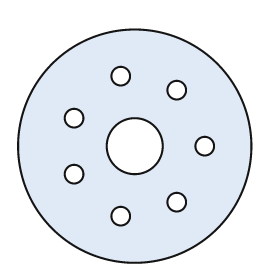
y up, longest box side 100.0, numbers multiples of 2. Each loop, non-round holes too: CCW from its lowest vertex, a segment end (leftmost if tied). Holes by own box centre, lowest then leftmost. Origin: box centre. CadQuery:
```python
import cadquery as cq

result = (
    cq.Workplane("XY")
    .moveTo(0.0, 0.0)
    .circle(50.0)
    .moveTo(-6.0, -30.0)
    .circle(4.0)
    .moveTo(18.0, -24.0)
    .circle(4.0)
    .moveTo(-26.0, -12.0)
    .circle(4.0)
    .moveTo(0.0, 0.0)
    .circle(12.0)
    .moveTo(30.0, 0.0)
    .circle(4.0)
    .moveTo(-26.0, 12.0)
    .circle(4.0)
    .moveTo(18.0, 24.0)
    .circle(4.0)
    .moveTo(-6.0, 30.0)
    .circle(4.0)
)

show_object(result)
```